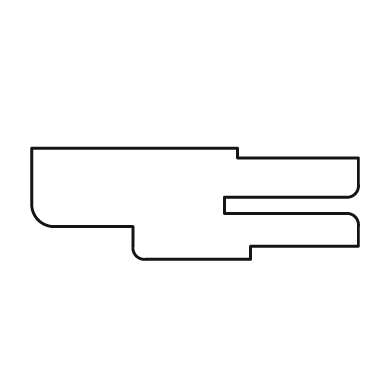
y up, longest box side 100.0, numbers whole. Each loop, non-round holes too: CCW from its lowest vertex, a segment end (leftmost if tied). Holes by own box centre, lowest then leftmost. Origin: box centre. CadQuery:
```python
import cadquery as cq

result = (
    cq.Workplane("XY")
    .moveTo(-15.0, -17.0)
    .lineTo(17.0, -17.0)
    .lineTo(17.0, -13.0)
    .lineTo(50.0, -13.0)
    .lineTo(50.0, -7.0)
    .threePointArc((49.0, -4.0), (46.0, -3.0))
    .lineTo(9.0, -3.0)
    .lineTo(9.0, 2.0)
    .lineTo(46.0, 2.0)
    .threePointArc((49.0, 3.0), (50.0, 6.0))
    .lineTo(50.0, 14.0)
    .lineTo(13.0, 14.0)
    .lineTo(13.0, 17.0)
    .lineTo(-50.0, 17.0)
    .lineTo(-50.0, 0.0)
    .threePointArc((-48.0, -5.0), (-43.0, -7.0))
    .lineTo(-19.0, -7.0)
    .lineTo(-19.0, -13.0)
    .threePointArc((-18.0, -16.0), (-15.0, -17.0))
    .close()
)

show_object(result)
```